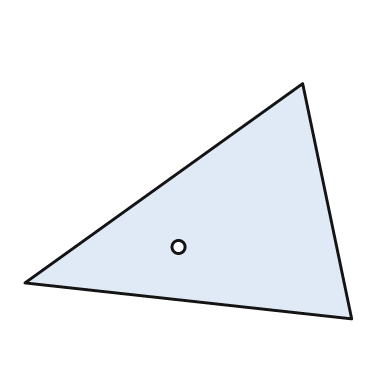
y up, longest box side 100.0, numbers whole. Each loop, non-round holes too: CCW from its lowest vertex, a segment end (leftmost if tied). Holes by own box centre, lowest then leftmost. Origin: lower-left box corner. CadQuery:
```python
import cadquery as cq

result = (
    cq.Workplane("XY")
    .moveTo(100.0, 0.0)
    .lineTo(85.0, 72.0)
    .lineTo(0.0, 11.0)
    .close()
    .moveTo(47.0, 22.0)
    .circle(2.0)
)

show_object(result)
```